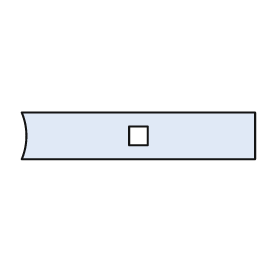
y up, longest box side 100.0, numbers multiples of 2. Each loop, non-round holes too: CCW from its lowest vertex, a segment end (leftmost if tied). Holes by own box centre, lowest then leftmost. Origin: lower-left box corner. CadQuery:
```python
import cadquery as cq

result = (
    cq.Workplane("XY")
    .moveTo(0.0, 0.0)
    .lineTo(100.0, 0.0)
    .lineTo(100.0, 20.0)
    .lineTo(0.0, 20.0)
    .threePointArc((2.0, 10.0), (0.0, 0.0))
    .close()
    .moveTo(46.0, 6.0)
    .lineTo(54.0, 6.0)
    .lineTo(54.0, 14.0)
    .lineTo(46.0, 14.0)
    .close()
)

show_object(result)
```